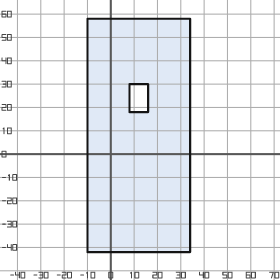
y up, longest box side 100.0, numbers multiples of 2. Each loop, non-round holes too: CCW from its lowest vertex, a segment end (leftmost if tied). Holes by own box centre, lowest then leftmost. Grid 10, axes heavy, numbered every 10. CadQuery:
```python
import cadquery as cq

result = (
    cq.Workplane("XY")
    .moveTo(-10.0, -42.0)
    .lineTo(34.0, -42.0)
    .lineTo(34.0, 58.0)
    .lineTo(-10.0, 58.0)
    .close()
    .moveTo(8.0, 18.0)
    .lineTo(16.0, 18.0)
    .lineTo(16.0, 30.0)
    .lineTo(8.0, 30.0)
    .close()
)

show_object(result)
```